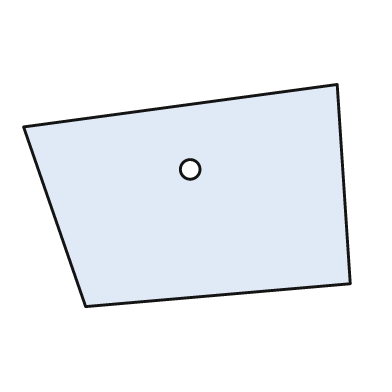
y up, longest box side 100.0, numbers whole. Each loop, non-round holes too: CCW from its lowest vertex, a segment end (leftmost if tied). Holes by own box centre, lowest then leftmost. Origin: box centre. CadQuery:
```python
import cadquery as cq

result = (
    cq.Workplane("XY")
    .moveTo(-31.0, -34.0)
    .lineTo(50.0, -27.0)
    .lineTo(46.0, 34.0)
    .lineTo(-50.0, 21.0)
    .close()
    .moveTo(1.0, 8.0)
    .circle(3.0)
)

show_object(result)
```